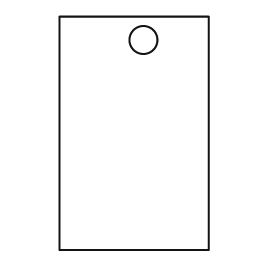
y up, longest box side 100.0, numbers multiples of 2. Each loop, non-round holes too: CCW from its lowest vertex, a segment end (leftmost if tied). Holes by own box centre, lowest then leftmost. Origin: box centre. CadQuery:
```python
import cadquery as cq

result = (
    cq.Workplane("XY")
    .moveTo(-32.0, -50.0)
    .lineTo(32.0, -50.0)
    .lineTo(32.0, 50.0)
    .lineTo(-32.0, 50.0)
    .close()
    .moveTo(4.0, 40.0)
    .circle(6.0)
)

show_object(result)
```